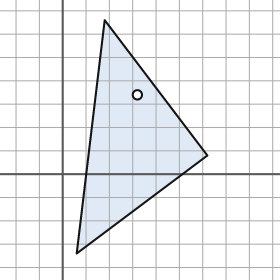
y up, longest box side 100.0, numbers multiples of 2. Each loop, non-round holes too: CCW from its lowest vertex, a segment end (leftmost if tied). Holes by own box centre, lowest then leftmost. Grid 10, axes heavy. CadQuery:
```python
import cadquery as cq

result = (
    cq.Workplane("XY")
    .moveTo(6.0, -34.0)
    .lineTo(62.0, 8.0)
    .lineTo(18.0, 66.0)
    .close()
    .moveTo(32.0, 34.0)
    .circle(2.0)
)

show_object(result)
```